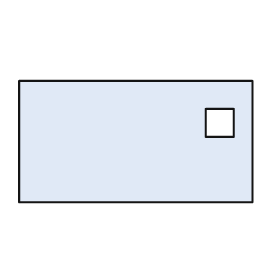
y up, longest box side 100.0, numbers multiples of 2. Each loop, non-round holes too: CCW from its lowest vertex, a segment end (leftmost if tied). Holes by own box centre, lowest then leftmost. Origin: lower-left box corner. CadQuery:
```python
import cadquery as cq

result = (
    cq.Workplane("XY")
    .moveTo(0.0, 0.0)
    .lineTo(100.0, 0.0)
    .lineTo(100.0, 52.0)
    .lineTo(0.0, 52.0)
    .close()
    .moveTo(80.0, 28.0)
    .lineTo(92.0, 28.0)
    .lineTo(92.0, 40.0)
    .lineTo(80.0, 40.0)
    .close()
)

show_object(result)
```